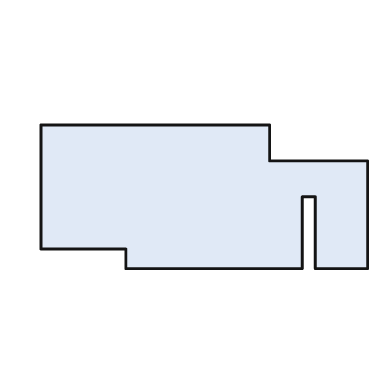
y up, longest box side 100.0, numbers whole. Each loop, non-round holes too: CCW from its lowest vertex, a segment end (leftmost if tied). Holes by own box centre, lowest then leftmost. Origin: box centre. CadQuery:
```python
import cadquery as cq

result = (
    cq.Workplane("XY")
    .moveTo(-24.0, -22.0)
    .lineTo(30.0, -22.0)
    .lineTo(30.0, 0.0)
    .lineTo(34.0, 0.0)
    .lineTo(34.0, -22.0)
    .lineTo(50.0, -22.0)
    .lineTo(50.0, 11.0)
    .lineTo(20.0, 11.0)
    .lineTo(20.0, 22.0)
    .lineTo(-50.0, 22.0)
    .lineTo(-50.0, -16.0)
    .lineTo(-24.0, -16.0)
    .close()
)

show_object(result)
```